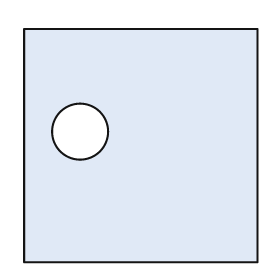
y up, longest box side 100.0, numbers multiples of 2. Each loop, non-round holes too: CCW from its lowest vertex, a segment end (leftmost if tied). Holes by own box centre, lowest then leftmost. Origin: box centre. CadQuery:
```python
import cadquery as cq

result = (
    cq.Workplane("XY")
    .moveTo(-50.0, -50.0)
    .lineTo(50.0, -50.0)
    .lineTo(50.0, 50.0)
    .lineTo(-50.0, 50.0)
    .close()
    .moveTo(-26.0, 6.0)
    .circle(12.0)
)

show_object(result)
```